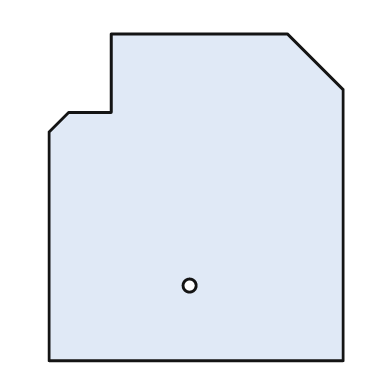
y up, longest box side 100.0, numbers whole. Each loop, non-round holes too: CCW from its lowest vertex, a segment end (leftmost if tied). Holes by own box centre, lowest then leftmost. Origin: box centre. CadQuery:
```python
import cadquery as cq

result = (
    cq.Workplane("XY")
    .moveTo(-45.0, -50.0)
    .lineTo(45.0, -50.0)
    .lineTo(45.0, 33.0)
    .lineTo(28.0, 50.0)
    .lineTo(-26.0, 50.0)
    .lineTo(-26.0, 26.0)
    .lineTo(-39.0, 26.0)
    .lineTo(-45.0, 20.0)
    .close()
    .moveTo(-2.0, -27.0)
    .circle(2.0)
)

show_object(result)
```